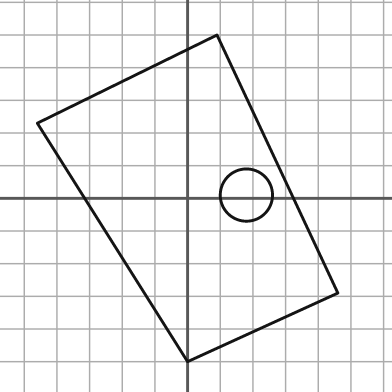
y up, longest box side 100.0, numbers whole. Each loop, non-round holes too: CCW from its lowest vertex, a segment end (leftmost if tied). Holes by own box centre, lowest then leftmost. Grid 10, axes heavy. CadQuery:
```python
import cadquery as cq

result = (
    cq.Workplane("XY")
    .moveTo(0.0, -50.0)
    .lineTo(46.0, -29.0)
    .lineTo(9.0, 50.0)
    .lineTo(-46.0, 23.0)
    .close()
    .moveTo(18.0, 1.0)
    .circle(8.0)
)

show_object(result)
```